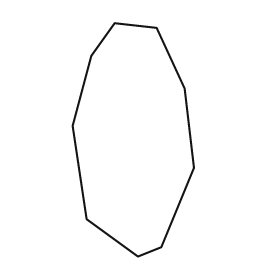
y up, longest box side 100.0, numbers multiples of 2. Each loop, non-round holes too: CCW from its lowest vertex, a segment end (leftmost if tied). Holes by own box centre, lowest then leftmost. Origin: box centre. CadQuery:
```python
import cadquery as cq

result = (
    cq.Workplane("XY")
    .moveTo(2.0, -50.0)
    .lineTo(12.0, -46.0)
    .lineTo(26.0, -12.0)
    .lineTo(22.0, 22.0)
    .lineTo(10.0, 48.0)
    .lineTo(-8.0, 50.0)
    .lineTo(-18.0, 36.0)
    .lineTo(-26.0, 6.0)
    .lineTo(-20.0, -34.0)
    .close()
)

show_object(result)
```